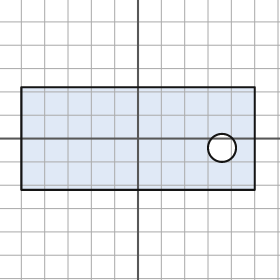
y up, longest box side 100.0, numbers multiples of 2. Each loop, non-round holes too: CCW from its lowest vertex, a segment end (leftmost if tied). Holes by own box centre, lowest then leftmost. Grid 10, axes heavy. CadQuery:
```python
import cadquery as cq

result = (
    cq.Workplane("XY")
    .moveTo(-50.0, -22.0)
    .lineTo(50.0, -22.0)
    .lineTo(50.0, 22.0)
    .lineTo(-50.0, 22.0)
    .close()
    .moveTo(36.0, -4.0)
    .circle(6.0)
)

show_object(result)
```